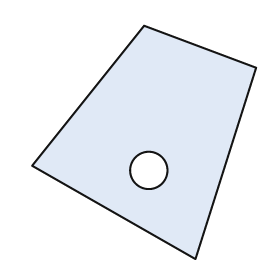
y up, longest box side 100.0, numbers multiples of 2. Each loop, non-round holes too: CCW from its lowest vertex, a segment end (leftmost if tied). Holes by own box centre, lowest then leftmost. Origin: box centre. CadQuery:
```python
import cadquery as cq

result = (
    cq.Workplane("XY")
    .moveTo(22.0, -50.0)
    .lineTo(48.0, 32.0)
    .lineTo(0.0, 50.0)
    .lineTo(-48.0, -10.0)
    .close()
    .moveTo(2.0, -12.0)
    .circle(8.0)
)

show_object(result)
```